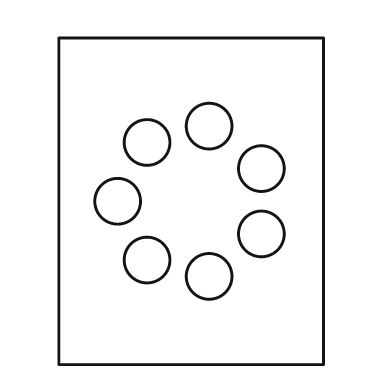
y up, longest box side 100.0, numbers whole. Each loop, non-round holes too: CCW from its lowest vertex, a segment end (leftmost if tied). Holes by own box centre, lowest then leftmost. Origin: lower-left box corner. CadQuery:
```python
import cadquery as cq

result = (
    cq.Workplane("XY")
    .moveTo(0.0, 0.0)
    .lineTo(81.0, 0.0)
    .lineTo(81.0, 100.0)
    .lineTo(0.0, 100.0)
    .close()
    .moveTo(46.0, 27.0)
    .circle(7.0)
    .moveTo(27.0, 32.0)
    .circle(7.0)
    .moveTo(62.0, 40.0)
    .circle(7.0)
    .moveTo(18.0, 50.0)
    .circle(7.0)
    .moveTo(62.0, 60.0)
    .circle(7.0)
    .moveTo(27.0, 68.0)
    .circle(7.0)
    .moveTo(46.0, 73.0)
    .circle(7.0)
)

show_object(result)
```